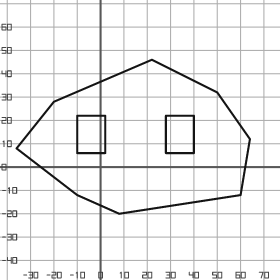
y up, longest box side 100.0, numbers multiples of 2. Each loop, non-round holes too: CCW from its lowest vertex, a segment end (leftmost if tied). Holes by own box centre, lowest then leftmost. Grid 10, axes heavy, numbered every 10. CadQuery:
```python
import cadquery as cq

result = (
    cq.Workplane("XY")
    .moveTo(8.0, -20.0)
    .lineTo(60.0, -12.0)
    .lineTo(64.0, 12.0)
    .lineTo(50.0, 32.0)
    .lineTo(22.0, 46.0)
    .lineTo(-20.0, 28.0)
    .lineTo(-36.0, 8.0)
    .lineTo(-10.0, -12.0)
    .close()
    .moveTo(-10.0, 6.0)
    .lineTo(2.0, 6.0)
    .lineTo(2.0, 22.0)
    .lineTo(-10.0, 22.0)
    .close()
    .moveTo(28.0, 6.0)
    .lineTo(40.0, 6.0)
    .lineTo(40.0, 22.0)
    .lineTo(28.0, 22.0)
    .close()
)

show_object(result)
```